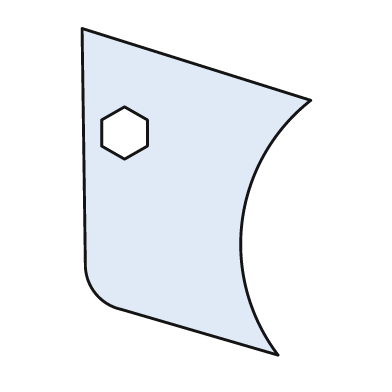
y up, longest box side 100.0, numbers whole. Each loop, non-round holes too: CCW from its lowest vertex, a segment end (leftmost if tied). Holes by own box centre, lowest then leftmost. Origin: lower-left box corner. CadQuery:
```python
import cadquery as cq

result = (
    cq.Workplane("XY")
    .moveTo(60.0, 0.0)
    .threePointArc((49.0, 41.0), (70.0, 78.0))
    .lineTo(0.0, 100.0)
    .lineTo(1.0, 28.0)
    .threePointArc((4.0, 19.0), (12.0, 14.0))
    .close()
    .moveTo(13.0, 60.0)
    .lineTo(20.0, 64.0)
    .lineTo(20.0, 72.0)
    .lineTo(13.0, 76.0)
    .lineTo(6.0, 72.0)
    .lineTo(6.0, 64.0)
    .close()
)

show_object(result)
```